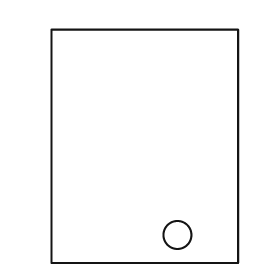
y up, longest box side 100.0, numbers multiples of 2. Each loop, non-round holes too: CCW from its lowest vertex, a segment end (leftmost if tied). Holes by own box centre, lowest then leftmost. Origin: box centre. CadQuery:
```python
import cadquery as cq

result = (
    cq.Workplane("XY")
    .moveTo(-40.0, -50.0)
    .lineTo(40.0, -50.0)
    .lineTo(40.0, 50.0)
    .lineTo(-40.0, 50.0)
    .close()
    .moveTo(14.0, -38.0)
    .circle(6.0)
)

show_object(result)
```